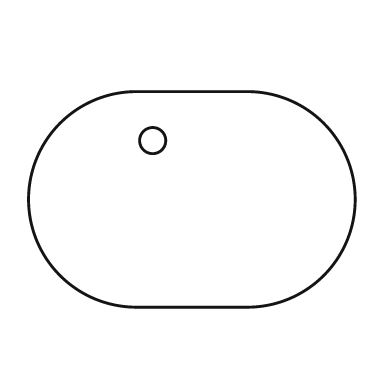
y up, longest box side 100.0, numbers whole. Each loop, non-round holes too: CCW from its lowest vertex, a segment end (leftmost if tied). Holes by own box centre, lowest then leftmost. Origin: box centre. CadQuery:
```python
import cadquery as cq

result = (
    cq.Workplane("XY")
    .moveTo(-17.0, -33.0)
    .lineTo(17.0, -33.0)
    .threePointArc((50.0, 0.0), (17.0, 33.0))
    .lineTo(-17.0, 33.0)
    .threePointArc((-50.0, 0.0), (-17.0, -33.0))
    .close()
    .moveTo(-12.0, 18.0)
    .circle(4.0)
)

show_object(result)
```